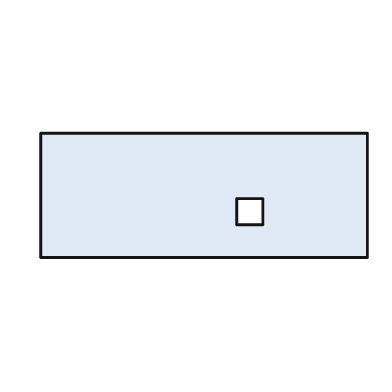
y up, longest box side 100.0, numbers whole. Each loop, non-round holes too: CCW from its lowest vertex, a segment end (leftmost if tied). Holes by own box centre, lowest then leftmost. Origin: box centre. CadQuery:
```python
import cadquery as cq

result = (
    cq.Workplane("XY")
    .moveTo(-50.0, -19.0)
    .lineTo(50.0, -19.0)
    .lineTo(50.0, 19.0)
    .lineTo(-50.0, 19.0)
    .close()
    .moveTo(10.0, -9.0)
    .lineTo(18.0, -9.0)
    .lineTo(18.0, -1.0)
    .lineTo(10.0, -1.0)
    .close()
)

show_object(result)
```